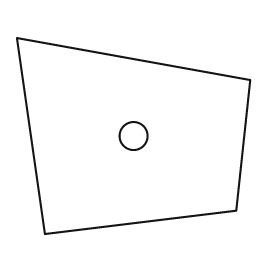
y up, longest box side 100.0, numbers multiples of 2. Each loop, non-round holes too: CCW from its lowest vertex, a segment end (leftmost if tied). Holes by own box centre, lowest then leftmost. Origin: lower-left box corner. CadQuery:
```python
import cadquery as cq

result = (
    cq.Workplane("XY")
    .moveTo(12.0, 0.0)
    .lineTo(94.0, 10.0)
    .lineTo(100.0, 66.0)
    .lineTo(0.0, 84.0)
    .close()
    .moveTo(50.0, 42.0)
    .circle(6.0)
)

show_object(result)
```